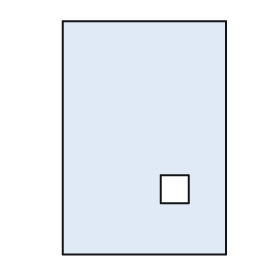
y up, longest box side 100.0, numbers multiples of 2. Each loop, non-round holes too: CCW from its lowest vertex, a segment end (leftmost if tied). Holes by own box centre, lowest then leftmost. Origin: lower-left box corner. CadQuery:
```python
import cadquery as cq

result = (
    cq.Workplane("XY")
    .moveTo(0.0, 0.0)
    .lineTo(70.0, 0.0)
    .lineTo(70.0, 100.0)
    .lineTo(0.0, 100.0)
    .close()
    .moveTo(42.0, 22.0)
    .lineTo(54.0, 22.0)
    .lineTo(54.0, 34.0)
    .lineTo(42.0, 34.0)
    .close()
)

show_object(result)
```